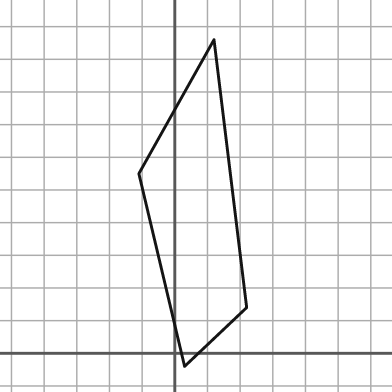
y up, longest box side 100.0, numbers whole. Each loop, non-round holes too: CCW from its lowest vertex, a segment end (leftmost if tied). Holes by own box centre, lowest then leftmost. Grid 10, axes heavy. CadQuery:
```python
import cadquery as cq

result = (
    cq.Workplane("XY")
    .moveTo(3.0, -4.0)
    .lineTo(22.0, 14.0)
    .lineTo(12.0, 96.0)
    .lineTo(-11.0, 55.0)
    .close()
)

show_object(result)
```